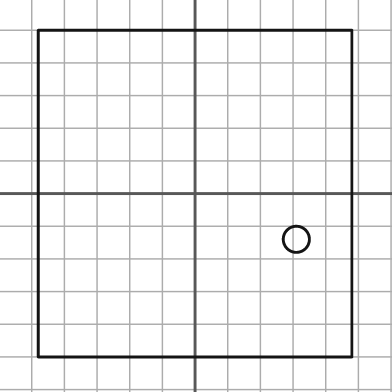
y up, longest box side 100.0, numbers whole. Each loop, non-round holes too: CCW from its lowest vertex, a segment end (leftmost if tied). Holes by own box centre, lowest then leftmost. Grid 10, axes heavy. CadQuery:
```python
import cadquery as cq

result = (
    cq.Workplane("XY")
    .moveTo(-48.0, -50.0)
    .lineTo(48.0, -50.0)
    .lineTo(48.0, 50.0)
    .lineTo(-48.0, 50.0)
    .close()
    .moveTo(31.0, -14.0)
    .circle(4.0)
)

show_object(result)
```